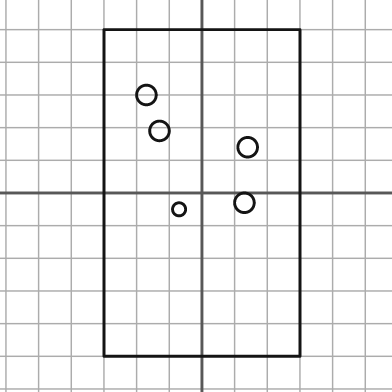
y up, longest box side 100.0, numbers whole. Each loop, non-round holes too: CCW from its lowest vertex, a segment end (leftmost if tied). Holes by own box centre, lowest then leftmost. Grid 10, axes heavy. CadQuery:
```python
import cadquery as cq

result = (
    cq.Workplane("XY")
    .moveTo(-30.0, -50.0)
    .lineTo(30.0, -50.0)
    .lineTo(30.0, 50.0)
    .lineTo(-30.0, 50.0)
    .close()
    .moveTo(-7.0, -5.0)
    .circle(2.0)
    .moveTo(13.0, -3.0)
    .circle(3.0)
    .moveTo(14.0, 14.0)
    .circle(3.0)
    .moveTo(-13.0, 19.0)
    .circle(3.0)
    .moveTo(-17.0, 30.0)
    .circle(3.0)
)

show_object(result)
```